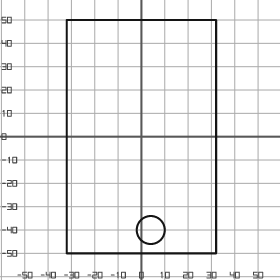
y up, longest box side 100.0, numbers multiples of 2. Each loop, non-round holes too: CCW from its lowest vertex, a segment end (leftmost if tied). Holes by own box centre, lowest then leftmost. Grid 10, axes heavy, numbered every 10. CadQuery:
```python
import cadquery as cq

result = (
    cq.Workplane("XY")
    .moveTo(-32.0, -50.0)
    .lineTo(32.0, -50.0)
    .lineTo(32.0, 50.0)
    .lineTo(-32.0, 50.0)
    .close()
    .moveTo(4.0, -40.0)
    .circle(6.0)
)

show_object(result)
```